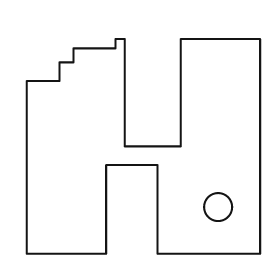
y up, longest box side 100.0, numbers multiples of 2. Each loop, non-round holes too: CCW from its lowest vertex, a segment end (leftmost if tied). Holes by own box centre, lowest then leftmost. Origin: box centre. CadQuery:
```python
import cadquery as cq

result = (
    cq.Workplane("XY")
    .moveTo(-50.0, -46.0)
    .lineTo(-16.0, -46.0)
    .lineTo(-16.0, -8.0)
    .lineTo(6.0, -8.0)
    .lineTo(6.0, -46.0)
    .lineTo(50.0, -46.0)
    .lineTo(50.0, 46.0)
    .lineTo(16.0, 46.0)
    .lineTo(16.0, 0.0)
    .lineTo(-8.0, 0.0)
    .lineTo(-8.0, 46.0)
    .lineTo(-12.0, 46.0)
    .lineTo(-12.0, 42.0)
    .lineTo(-30.0, 42.0)
    .lineTo(-30.0, 36.0)
    .lineTo(-36.0, 36.0)
    .lineTo(-36.0, 28.0)
    .lineTo(-50.0, 28.0)
    .close()
    .moveTo(32.0, -26.0)
    .circle(6.0)
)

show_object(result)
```